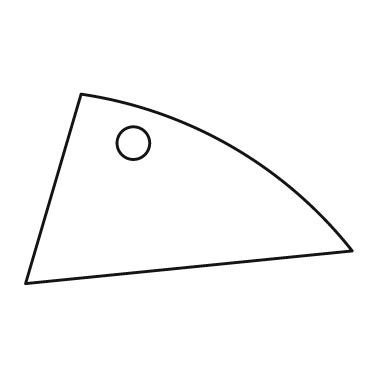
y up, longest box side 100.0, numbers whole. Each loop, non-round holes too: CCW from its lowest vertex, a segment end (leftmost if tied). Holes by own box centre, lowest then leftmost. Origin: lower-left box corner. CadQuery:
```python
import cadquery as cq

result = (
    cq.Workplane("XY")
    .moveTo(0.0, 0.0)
    .lineTo(100.0, 10.0)
    .threePointArc((63.0, 42.0), (17.0, 58.0))
    .close()
    .moveTo(33.0, 43.0)
    .circle(5.0)
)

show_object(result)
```